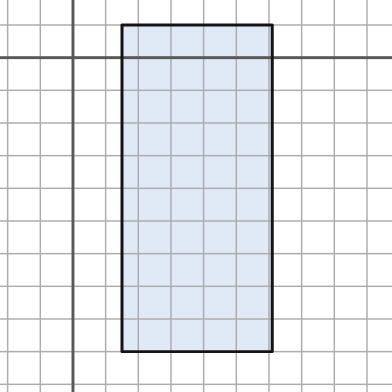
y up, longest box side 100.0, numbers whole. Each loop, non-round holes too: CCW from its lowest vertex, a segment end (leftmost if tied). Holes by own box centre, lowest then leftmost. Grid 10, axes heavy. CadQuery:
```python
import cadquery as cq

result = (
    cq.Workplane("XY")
    .moveTo(15.0, -90.0)
    .lineTo(61.0, -90.0)
    .lineTo(61.0, 10.0)
    .lineTo(15.0, 10.0)
    .close()
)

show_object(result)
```